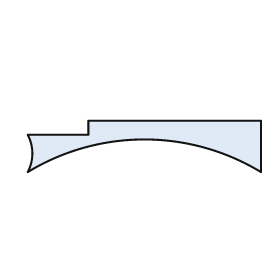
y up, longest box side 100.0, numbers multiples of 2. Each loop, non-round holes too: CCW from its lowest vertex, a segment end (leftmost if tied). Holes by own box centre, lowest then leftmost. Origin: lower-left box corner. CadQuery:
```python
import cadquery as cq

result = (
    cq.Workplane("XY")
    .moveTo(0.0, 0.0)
    .threePointArc((50.0, 14.0), (100.0, 0.0))
    .lineTo(100.0, 22.0)
    .lineTo(26.0, 22.0)
    .lineTo(26.0, 16.0)
    .lineTo(0.0, 16.0)
    .threePointArc((2.0, 8.0), (0.0, 0.0))
    .close()
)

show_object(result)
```